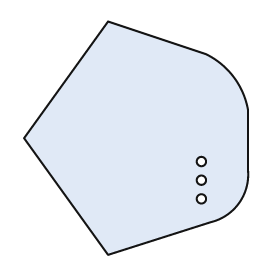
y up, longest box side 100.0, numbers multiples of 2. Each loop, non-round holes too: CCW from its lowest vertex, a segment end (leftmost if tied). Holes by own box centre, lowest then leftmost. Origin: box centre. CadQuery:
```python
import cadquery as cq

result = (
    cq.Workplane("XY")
    .moveTo(-12.0, -50.0)
    .lineTo(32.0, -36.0)
    .threePointArc((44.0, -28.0), (48.0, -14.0))
    .lineTo(48.0, 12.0)
    .threePointArc((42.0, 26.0), (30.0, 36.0))
    .lineTo(-12.0, 50.0)
    .lineTo(-48.0, 0.0)
    .close()
    .moveTo(28.0, -26.0)
    .circle(2.0)
    .moveTo(28.0, -18.0)
    .circle(2.0)
    .moveTo(28.0, -10.0)
    .circle(2.0)
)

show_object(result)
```